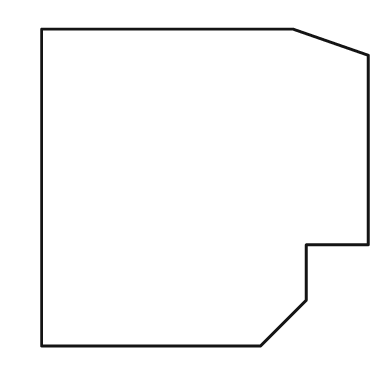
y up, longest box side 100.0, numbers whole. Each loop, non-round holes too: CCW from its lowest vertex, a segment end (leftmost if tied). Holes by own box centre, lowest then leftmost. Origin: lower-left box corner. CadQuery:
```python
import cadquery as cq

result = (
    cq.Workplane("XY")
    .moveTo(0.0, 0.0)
    .lineTo(67.0, 0.0)
    .lineTo(81.0, 14.0)
    .lineTo(81.0, 31.0)
    .lineTo(100.0, 31.0)
    .lineTo(100.0, 89.0)
    .lineTo(77.0, 97.0)
    .lineTo(0.0, 97.0)
    .close()
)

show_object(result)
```